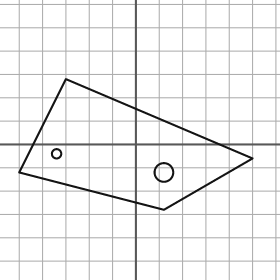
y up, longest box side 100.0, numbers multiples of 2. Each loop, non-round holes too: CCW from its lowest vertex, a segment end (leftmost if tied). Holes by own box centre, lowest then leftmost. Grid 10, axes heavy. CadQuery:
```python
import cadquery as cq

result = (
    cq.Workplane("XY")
    .moveTo(12.0, -28.0)
    .lineTo(50.0, -6.0)
    .lineTo(-30.0, 28.0)
    .lineTo(-50.0, -12.0)
    .close()
    .moveTo(12.0, -12.0)
    .circle(4.0)
    .moveTo(-34.0, -4.0)
    .circle(2.0)
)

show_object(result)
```